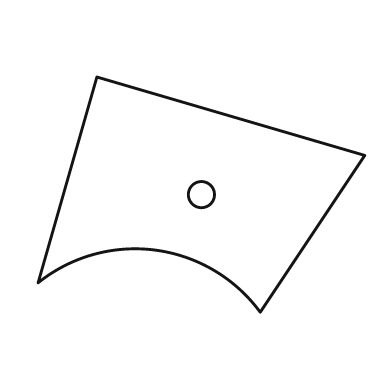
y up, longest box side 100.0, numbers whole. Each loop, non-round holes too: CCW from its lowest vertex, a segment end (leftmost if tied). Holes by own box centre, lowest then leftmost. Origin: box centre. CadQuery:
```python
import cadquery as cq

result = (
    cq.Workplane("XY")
    .moveTo(18.0, -36.0)
    .lineTo(50.0, 12.0)
    .lineTo(-32.0, 36.0)
    .lineTo(-50.0, -27.0)
    .threePointArc((-14.0, -17.0), (18.0, -36.0))
    .close()
    .moveTo(0.0, 0.0)
    .circle(4.0)
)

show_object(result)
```